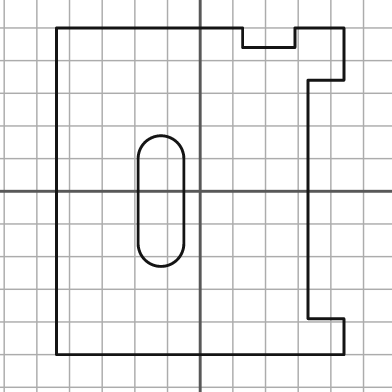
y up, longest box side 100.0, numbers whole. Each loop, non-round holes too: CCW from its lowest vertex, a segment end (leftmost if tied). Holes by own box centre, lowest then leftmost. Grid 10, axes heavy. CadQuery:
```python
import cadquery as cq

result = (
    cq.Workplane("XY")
    .moveTo(-44.0, -50.0)
    .lineTo(44.0, -50.0)
    .lineTo(44.0, -39.0)
    .lineTo(33.0, -39.0)
    .lineTo(33.0, 34.0)
    .lineTo(44.0, 34.0)
    .lineTo(44.0, 50.0)
    .lineTo(29.0, 50.0)
    .lineTo(29.0, 44.0)
    .lineTo(13.0, 44.0)
    .lineTo(13.0, 50.0)
    .lineTo(-44.0, 50.0)
    .close()
    .moveTo(-19.0, -16.0)
    .threePointArc((-12.0, -23.0), (-5.0, -16.0))
    .lineTo(-5.0, 10.0)
    .threePointArc((-12.0, 17.0), (-19.0, 10.0))
    .close()
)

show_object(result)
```